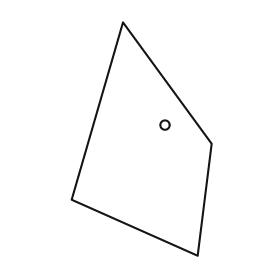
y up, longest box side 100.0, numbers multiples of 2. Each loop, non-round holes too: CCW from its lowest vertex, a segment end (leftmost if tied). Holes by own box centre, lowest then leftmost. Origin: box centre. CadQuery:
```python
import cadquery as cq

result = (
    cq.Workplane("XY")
    .moveTo(24.0, -50.0)
    .lineTo(30.0, -2.0)
    .lineTo(-8.0, 50.0)
    .lineTo(-30.0, -26.0)
    .close()
    .moveTo(10.0, 6.0)
    .circle(2.0)
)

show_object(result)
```